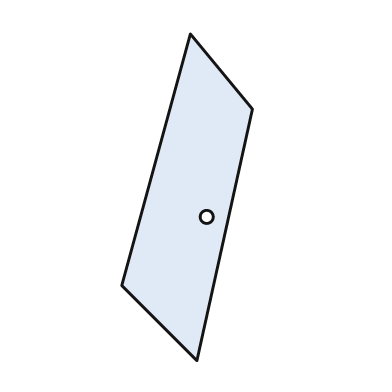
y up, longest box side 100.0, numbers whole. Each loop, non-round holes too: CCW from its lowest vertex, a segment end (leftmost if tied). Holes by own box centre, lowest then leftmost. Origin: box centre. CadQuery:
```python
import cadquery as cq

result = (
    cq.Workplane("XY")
    .moveTo(3.0, -50.0)
    .lineTo(20.0, 27.0)
    .lineTo(1.0, 50.0)
    .lineTo(-20.0, -27.0)
    .close()
    .moveTo(6.0, -6.0)
    .circle(2.0)
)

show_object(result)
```